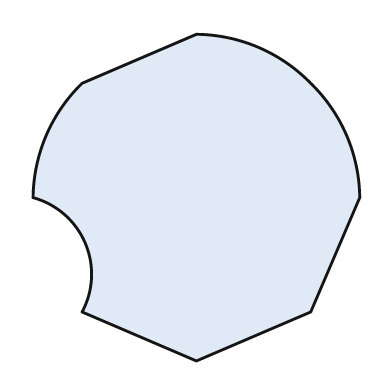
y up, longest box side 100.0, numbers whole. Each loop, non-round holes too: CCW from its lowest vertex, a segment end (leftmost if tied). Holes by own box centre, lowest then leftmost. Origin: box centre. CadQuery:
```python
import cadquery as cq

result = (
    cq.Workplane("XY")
    .moveTo(0.0, -50.0)
    .lineTo(35.0, -35.0)
    .lineTo(50.0, 0.0)
    .threePointArc((46.0, 19.0), (35.0, 35.0))
    .threePointArc((19.0, 46.0), (0.0, 50.0))
    .lineTo(-35.0, 35.0)
    .threePointArc((-46.0, 19.0), (-50.0, 0.0))
    .threePointArc((-34.0, -14.0), (-35.0, -35.0))
    .close()
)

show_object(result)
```